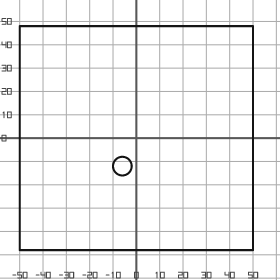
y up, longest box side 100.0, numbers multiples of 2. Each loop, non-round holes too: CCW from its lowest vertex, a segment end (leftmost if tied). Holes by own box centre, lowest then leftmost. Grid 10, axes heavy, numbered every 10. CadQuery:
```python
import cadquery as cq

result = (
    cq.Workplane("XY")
    .moveTo(-50.0, -48.0)
    .lineTo(50.0, -48.0)
    .lineTo(50.0, 48.0)
    .lineTo(-50.0, 48.0)
    .close()
    .moveTo(-6.0, -12.0)
    .circle(4.0)
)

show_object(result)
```